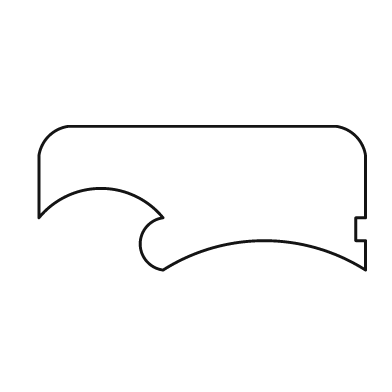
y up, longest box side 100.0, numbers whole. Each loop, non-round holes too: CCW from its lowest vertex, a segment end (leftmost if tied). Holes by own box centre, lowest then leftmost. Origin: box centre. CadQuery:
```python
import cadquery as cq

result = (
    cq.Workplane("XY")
    .moveTo(-12.0, -22.0)
    .threePointArc((19.0, -13.0), (50.0, -22.0))
    .lineTo(50.0, -13.0)
    .lineTo(47.0, -13.0)
    .lineTo(47.0, -6.0)
    .lineTo(50.0, -6.0)
    .lineTo(50.0, 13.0)
    .threePointArc((47.0, 19.0), (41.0, 22.0))
    .lineTo(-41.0, 22.0)
    .threePointArc((-47.0, 19.0), (-50.0, 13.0))
    .lineTo(-50.0, -6.0)
    .threePointArc((-31.0, 3.0), (-12.0, -6.0))
    .threePointArc((-19.0, -14.0), (-12.0, -22.0))
    .close()
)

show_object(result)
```